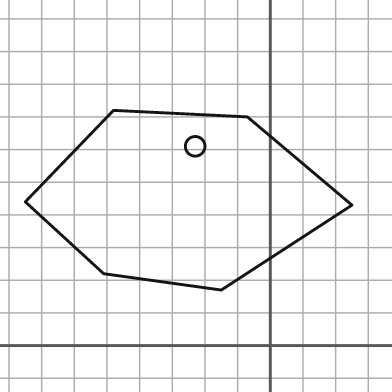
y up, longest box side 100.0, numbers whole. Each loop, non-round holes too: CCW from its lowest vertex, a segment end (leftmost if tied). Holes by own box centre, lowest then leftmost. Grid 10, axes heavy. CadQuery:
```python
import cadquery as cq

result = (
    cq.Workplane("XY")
    .moveTo(-15.0, 17.0)
    .lineTo(25.0, 43.0)
    .lineTo(-7.0, 70.0)
    .lineTo(-48.0, 72.0)
    .lineTo(-75.0, 44.0)
    .lineTo(-51.0, 22.0)
    .close()
    .moveTo(-23.0, 61.0)
    .circle(3.0)
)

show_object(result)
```